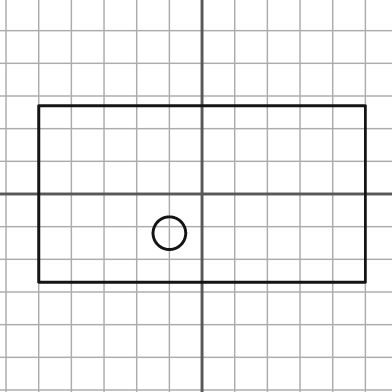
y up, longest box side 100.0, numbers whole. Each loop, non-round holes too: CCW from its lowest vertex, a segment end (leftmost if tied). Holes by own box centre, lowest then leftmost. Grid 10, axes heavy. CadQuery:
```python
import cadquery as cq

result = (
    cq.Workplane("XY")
    .moveTo(-50.0, -27.0)
    .lineTo(50.0, -27.0)
    .lineTo(50.0, 27.0)
    .lineTo(-50.0, 27.0)
    .close()
    .moveTo(-10.0, -12.0)
    .circle(5.0)
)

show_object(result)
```